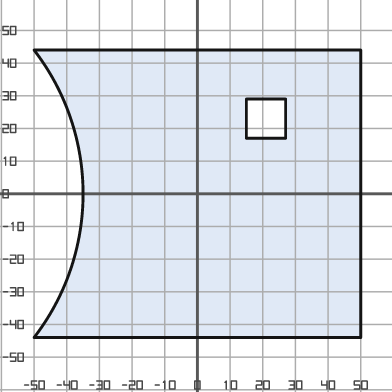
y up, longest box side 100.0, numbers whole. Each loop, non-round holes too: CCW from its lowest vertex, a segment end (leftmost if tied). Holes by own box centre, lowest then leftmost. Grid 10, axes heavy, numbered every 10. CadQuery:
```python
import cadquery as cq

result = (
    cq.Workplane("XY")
    .moveTo(-50.0, -44.0)
    .lineTo(50.0, -44.0)
    .lineTo(50.0, 44.0)
    .lineTo(-50.0, 44.0)
    .threePointArc((-35.0, 0.0), (-50.0, -44.0))
    .close()
    .moveTo(15.0, 17.0)
    .lineTo(27.0, 17.0)
    .lineTo(27.0, 29.0)
    .lineTo(15.0, 29.0)
    .close()
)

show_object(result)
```